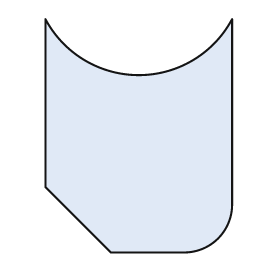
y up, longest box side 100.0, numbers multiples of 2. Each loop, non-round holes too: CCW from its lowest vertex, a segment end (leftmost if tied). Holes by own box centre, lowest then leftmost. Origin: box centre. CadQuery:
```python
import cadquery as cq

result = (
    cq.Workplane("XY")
    .moveTo(-12.0, -50.0)
    .lineTo(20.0, -50.0)
    .threePointArc((34.0, -44.0), (40.0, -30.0))
    .lineTo(40.0, 50.0)
    .threePointArc((0.0, 26.0), (-40.0, 50.0))
    .lineTo(-40.0, -22.0)
    .close()
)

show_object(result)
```